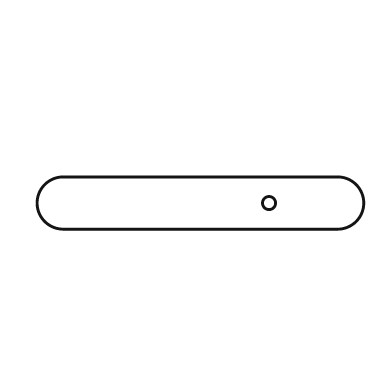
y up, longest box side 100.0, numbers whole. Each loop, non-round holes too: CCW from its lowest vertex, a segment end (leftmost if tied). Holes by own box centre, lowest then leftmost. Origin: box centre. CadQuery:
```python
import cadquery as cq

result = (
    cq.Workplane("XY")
    .moveTo(-42.0, -8.0)
    .lineTo(42.0, -8.0)
    .threePointArc((50.0, 0.0), (42.0, 8.0))
    .lineTo(-42.0, 8.0)
    .threePointArc((-50.0, 0.0), (-42.0, -8.0))
    .close()
    .moveTo(21.0, 0.0)
    .circle(2.0)
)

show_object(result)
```